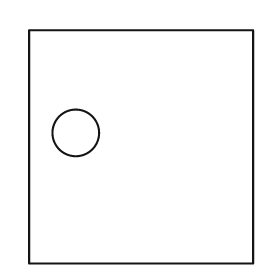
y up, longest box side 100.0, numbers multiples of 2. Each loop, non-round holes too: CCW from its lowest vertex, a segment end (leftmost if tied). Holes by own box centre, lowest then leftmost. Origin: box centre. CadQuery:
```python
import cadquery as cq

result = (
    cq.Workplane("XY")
    .moveTo(-48.0, -50.0)
    .lineTo(48.0, -50.0)
    .lineTo(48.0, 50.0)
    .lineTo(-48.0, 50.0)
    .close()
    .moveTo(-28.0, 6.0)
    .circle(10.0)
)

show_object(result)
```